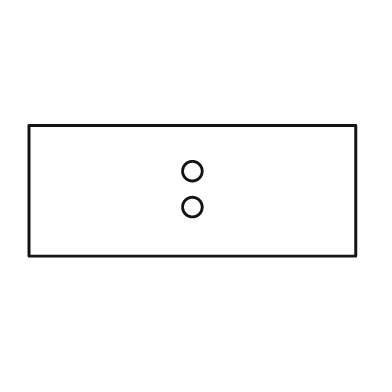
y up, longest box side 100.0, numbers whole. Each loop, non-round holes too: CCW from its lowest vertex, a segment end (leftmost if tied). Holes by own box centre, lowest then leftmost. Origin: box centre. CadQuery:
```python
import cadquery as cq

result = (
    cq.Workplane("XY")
    .moveTo(-50.0, -20.0)
    .lineTo(50.0, -20.0)
    .lineTo(50.0, 20.0)
    .lineTo(-50.0, 20.0)
    .close()
    .moveTo(0.0, -5.0)
    .circle(3.0)
    .moveTo(0.0, 6.0)
    .circle(3.0)
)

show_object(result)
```